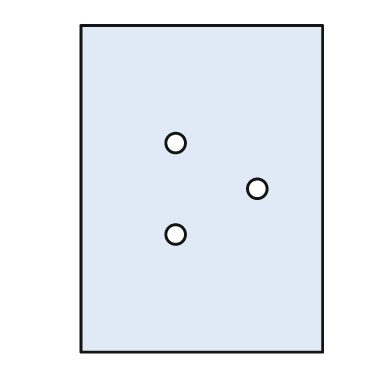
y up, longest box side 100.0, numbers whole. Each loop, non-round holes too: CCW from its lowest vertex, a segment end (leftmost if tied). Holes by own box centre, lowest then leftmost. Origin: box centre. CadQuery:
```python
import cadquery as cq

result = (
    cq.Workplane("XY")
    .moveTo(-37.0, -50.0)
    .lineTo(37.0, -50.0)
    .lineTo(37.0, 50.0)
    .lineTo(-37.0, 50.0)
    .close()
    .moveTo(-8.0, -14.0)
    .circle(3.0)
    .moveTo(17.0, 0.0)
    .circle(3.0)
    .moveTo(-8.0, 14.0)
    .circle(3.0)
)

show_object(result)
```